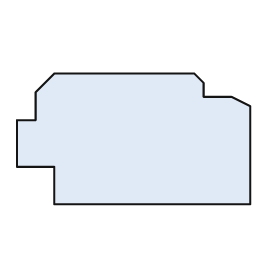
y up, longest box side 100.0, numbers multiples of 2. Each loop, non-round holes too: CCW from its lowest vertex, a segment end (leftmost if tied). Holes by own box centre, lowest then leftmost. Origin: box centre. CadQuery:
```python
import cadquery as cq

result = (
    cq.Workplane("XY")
    .moveTo(-34.0, -28.0)
    .lineTo(50.0, -28.0)
    .lineTo(50.0, 14.0)
    .lineTo(42.0, 18.0)
    .lineTo(30.0, 18.0)
    .lineTo(30.0, 24.0)
    .lineTo(26.0, 28.0)
    .lineTo(-34.0, 28.0)
    .lineTo(-42.0, 20.0)
    .lineTo(-42.0, 8.0)
    .lineTo(-50.0, 8.0)
    .lineTo(-50.0, -12.0)
    .lineTo(-34.0, -12.0)
    .close()
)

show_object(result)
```